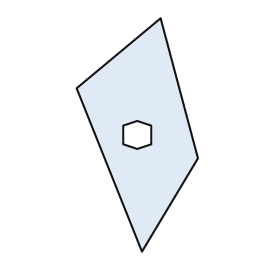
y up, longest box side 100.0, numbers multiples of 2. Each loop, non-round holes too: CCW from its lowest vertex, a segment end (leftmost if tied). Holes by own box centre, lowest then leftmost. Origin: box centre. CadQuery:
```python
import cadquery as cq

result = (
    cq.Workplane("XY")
    .moveTo(2.0, -50.0)
    .lineTo(26.0, -10.0)
    .lineTo(10.0, 50.0)
    .lineTo(-26.0, 20.0)
    .close()
    .moveTo(0.0, -6.0)
    .lineTo(6.0, -4.0)
    .lineTo(6.0, 4.0)
    .lineTo(0.0, 6.0)
    .lineTo(-6.0, 4.0)
    .lineTo(-6.0, -4.0)
    .close()
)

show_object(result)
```